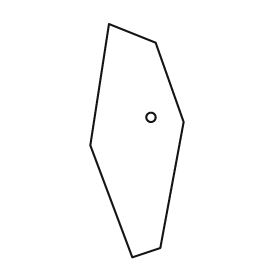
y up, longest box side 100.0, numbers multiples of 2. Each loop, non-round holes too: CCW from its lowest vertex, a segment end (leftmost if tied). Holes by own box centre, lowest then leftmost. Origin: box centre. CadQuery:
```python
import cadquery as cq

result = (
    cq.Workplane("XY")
    .moveTo(-2.0, -50.0)
    .lineTo(10.0, -46.0)
    .lineTo(20.0, 8.0)
    .lineTo(8.0, 42.0)
    .lineTo(-12.0, 50.0)
    .lineTo(-20.0, -2.0)
    .close()
    .moveTo(6.0, 10.0)
    .circle(2.0)
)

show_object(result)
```